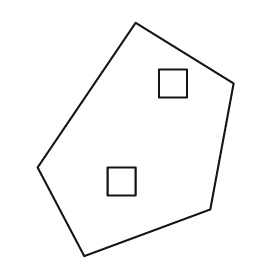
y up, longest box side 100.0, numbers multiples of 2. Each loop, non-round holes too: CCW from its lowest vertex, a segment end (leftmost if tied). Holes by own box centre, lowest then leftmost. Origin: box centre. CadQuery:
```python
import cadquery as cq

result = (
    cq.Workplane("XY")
    .moveTo(-22.0, -50.0)
    .lineTo(32.0, -30.0)
    .lineTo(42.0, 24.0)
    .lineTo(0.0, 50.0)
    .lineTo(-42.0, -12.0)
    .close()
    .moveTo(-12.0, -24.0)
    .lineTo(0.0, -24.0)
    .lineTo(0.0, -12.0)
    .lineTo(-12.0, -12.0)
    .close()
    .moveTo(10.0, 18.0)
    .lineTo(22.0, 18.0)
    .lineTo(22.0, 30.0)
    .lineTo(10.0, 30.0)
    .close()
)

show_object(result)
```